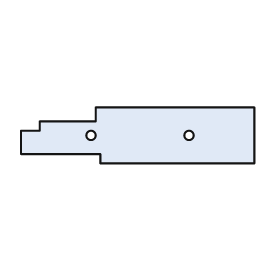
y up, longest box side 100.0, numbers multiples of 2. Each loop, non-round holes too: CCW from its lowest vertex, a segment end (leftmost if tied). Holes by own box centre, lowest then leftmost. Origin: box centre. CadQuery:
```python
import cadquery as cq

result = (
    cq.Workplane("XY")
    .moveTo(-16.0, -12.0)
    .lineTo(50.0, -12.0)
    .lineTo(50.0, 12.0)
    .lineTo(-18.0, 12.0)
    .lineTo(-18.0, 6.0)
    .lineTo(-42.0, 6.0)
    .lineTo(-42.0, 2.0)
    .lineTo(-50.0, 2.0)
    .lineTo(-50.0, -8.0)
    .lineTo(-16.0, -8.0)
    .close()
    .moveTo(-20.0, 0.0)
    .circle(2.0)
    .moveTo(22.0, 0.0)
    .circle(2.0)
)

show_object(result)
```